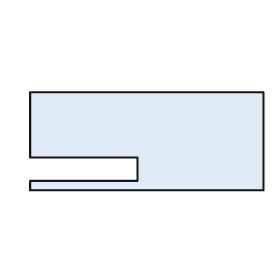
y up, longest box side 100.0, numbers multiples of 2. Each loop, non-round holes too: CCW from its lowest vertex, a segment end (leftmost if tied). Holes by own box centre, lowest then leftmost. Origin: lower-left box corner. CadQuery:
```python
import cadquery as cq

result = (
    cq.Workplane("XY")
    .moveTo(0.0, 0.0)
    .lineTo(100.0, 0.0)
    .lineTo(100.0, 42.0)
    .lineTo(0.0, 42.0)
    .lineTo(0.0, 14.0)
    .lineTo(46.0, 14.0)
    .lineTo(46.0, 4.0)
    .lineTo(0.0, 4.0)
    .close()
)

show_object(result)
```